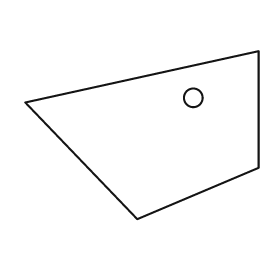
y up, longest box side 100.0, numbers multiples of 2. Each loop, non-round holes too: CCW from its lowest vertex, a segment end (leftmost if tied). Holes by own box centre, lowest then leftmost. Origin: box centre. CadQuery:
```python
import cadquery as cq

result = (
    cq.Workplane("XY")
    .moveTo(-2.0, -36.0)
    .lineTo(50.0, -14.0)
    .lineTo(50.0, 36.0)
    .lineTo(-50.0, 14.0)
    .close()
    .moveTo(22.0, 16.0)
    .circle(4.0)
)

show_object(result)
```